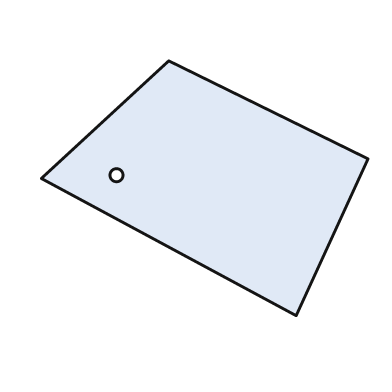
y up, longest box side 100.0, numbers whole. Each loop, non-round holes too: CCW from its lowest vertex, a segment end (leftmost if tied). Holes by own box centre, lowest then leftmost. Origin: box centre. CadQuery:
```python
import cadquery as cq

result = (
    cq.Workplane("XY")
    .moveTo(28.0, -39.0)
    .lineTo(50.0, 9.0)
    .lineTo(-11.0, 39.0)
    .lineTo(-50.0, 3.0)
    .close()
    .moveTo(-27.0, 4.0)
    .circle(2.0)
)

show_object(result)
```